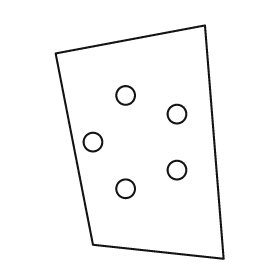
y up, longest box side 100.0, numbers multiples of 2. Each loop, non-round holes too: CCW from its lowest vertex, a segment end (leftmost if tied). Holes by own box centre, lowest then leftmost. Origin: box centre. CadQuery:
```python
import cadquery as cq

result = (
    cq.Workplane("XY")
    .moveTo(36.0, -50.0)
    .lineTo(28.0, 50.0)
    .lineTo(-36.0, 38.0)
    .lineTo(-20.0, -44.0)
    .close()
    .moveTo(-6.0, -20.0)
    .circle(4.0)
    .moveTo(16.0, -12.0)
    .circle(4.0)
    .moveTo(-20.0, 0.0)
    .circle(4.0)
    .moveTo(16.0, 12.0)
    .circle(4.0)
    .moveTo(-6.0, 20.0)
    .circle(4.0)
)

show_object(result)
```